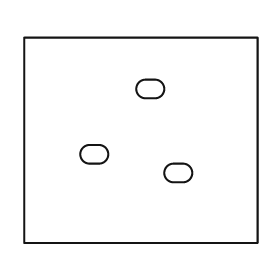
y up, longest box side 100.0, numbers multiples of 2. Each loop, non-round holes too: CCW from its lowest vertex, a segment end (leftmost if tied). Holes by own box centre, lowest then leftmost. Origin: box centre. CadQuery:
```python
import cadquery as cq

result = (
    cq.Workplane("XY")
    .moveTo(-50.0, -44.0)
    .lineTo(50.0, -44.0)
    .lineTo(50.0, 44.0)
    .lineTo(-50.0, 44.0)
    .close()
    .moveTo(14.0, -18.0)
    .lineTo(18.0, -18.0)
    .threePointArc((22.0, -14.0), (18.0, -10.0))
    .lineTo(14.0, -10.0)
    .threePointArc((10.0, -14.0), (14.0, -18.0))
    .close()
    .moveTo(-22.0, -10.0)
    .lineTo(-18.0, -10.0)
    .threePointArc((-14.0, -6.0), (-18.0, -2.0))
    .lineTo(-22.0, -2.0)
    .threePointArc((-26.0, -6.0), (-22.0, -10.0))
    .close()
    .moveTo(2.0, 18.0)
    .lineTo(6.0, 18.0)
    .threePointArc((10.0, 22.0), (6.0, 26.0))
    .lineTo(2.0, 26.0)
    .threePointArc((-2.0, 22.0), (2.0, 18.0))
    .close()
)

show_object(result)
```